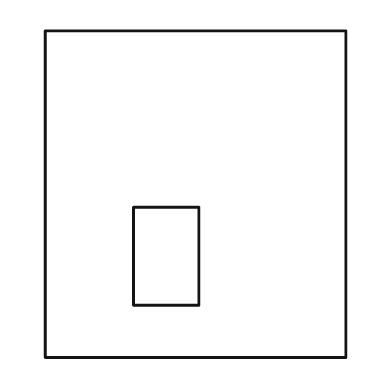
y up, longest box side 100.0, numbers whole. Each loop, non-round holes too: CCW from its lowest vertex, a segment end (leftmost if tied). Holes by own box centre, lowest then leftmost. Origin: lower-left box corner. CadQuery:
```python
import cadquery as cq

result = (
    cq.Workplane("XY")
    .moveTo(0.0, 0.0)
    .lineTo(92.0, 0.0)
    .lineTo(92.0, 100.0)
    .lineTo(0.0, 100.0)
    .close()
    .moveTo(27.0, 16.0)
    .lineTo(47.0, 16.0)
    .lineTo(47.0, 46.0)
    .lineTo(27.0, 46.0)
    .close()
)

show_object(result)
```